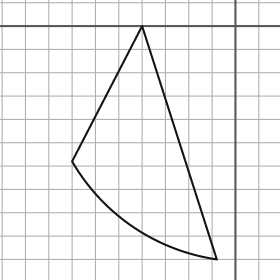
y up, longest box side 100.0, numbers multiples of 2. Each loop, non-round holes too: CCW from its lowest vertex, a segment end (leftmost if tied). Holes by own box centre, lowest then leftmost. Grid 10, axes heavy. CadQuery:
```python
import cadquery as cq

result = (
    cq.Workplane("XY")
    .moveTo(-8.0, -100.0)
    .lineTo(-40.0, 0.0)
    .lineTo(-70.0, -58.0)
    .threePointArc((-44.0, -86.0), (-8.0, -100.0))
    .close()
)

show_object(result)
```